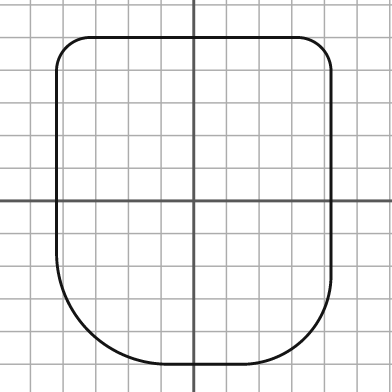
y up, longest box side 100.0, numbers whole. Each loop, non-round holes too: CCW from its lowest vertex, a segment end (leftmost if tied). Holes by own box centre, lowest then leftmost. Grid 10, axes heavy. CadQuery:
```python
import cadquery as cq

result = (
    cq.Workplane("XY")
    .moveTo(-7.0, -50.0)
    .lineTo(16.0, -50.0)
    .threePointArc((34.0, -42.0), (42.0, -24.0))
    .lineTo(42.0, 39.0)
    .threePointArc((39.0, 47.0), (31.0, 50.0))
    .lineTo(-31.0, 50.0)
    .threePointArc((-39.0, 47.0), (-42.0, 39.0))
    .lineTo(-42.0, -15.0)
    .threePointArc((-32.0, -40.0), (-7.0, -50.0))
    .close()
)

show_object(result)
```